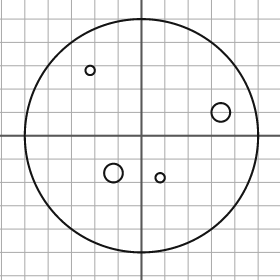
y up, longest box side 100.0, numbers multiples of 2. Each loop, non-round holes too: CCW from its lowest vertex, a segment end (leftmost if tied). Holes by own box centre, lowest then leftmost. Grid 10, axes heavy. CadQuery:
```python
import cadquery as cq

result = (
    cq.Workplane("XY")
    .moveTo(0.0, 0.0)
    .circle(50.0)
    .moveTo(8.0, -18.0)
    .circle(2.0)
    .moveTo(-12.0, -16.0)
    .circle(4.0)
    .moveTo(34.0, 10.0)
    .circle(4.0)
    .moveTo(-22.0, 28.0)
    .circle(2.0)
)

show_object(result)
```